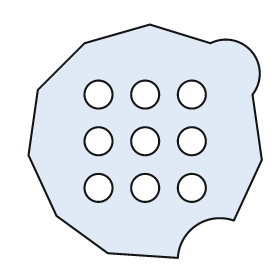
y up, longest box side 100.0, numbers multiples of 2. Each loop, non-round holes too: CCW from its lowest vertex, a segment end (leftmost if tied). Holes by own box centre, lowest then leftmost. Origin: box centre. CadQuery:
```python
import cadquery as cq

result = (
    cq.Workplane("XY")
    .moveTo(14.0, -50.0)
    .threePointArc((22.0, -36.0), (38.0, -34.0))
    .lineTo(50.0, -8.0)
    .lineTo(46.0, 20.0)
    .threePointArc((46.0, 38.0), (28.0, 42.0))
    .lineTo(2.0, 50.0)
    .lineTo(-26.0, 42.0)
    .lineTo(-46.0, 22.0)
    .lineTo(-50.0, -6.0)
    .lineTo(-38.0, -32.0)
    .lineTo(-16.0, -48.0)
    .close()
    .moveTo(-20.0, -20.0)
    .circle(6.0)
    .moveTo(0.0, -20.0)
    .circle(6.0)
    .moveTo(20.0, -20.0)
    .circle(6.0)
    .moveTo(-20.0, 0.0)
    .circle(6.0)
    .moveTo(0.0, 0.0)
    .circle(6.0)
    .moveTo(20.0, 0.0)
    .circle(6.0)
    .moveTo(-20.0, 20.0)
    .circle(6.0)
    .moveTo(0.0, 20.0)
    .circle(6.0)
    .moveTo(20.0, 20.0)
    .circle(6.0)
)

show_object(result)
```